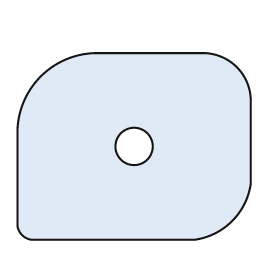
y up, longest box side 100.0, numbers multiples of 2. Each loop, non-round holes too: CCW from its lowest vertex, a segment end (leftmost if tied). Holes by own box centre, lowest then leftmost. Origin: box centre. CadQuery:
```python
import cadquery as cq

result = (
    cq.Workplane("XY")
    .moveTo(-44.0, -40.0)
    .lineTo(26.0, -40.0)
    .threePointArc((42.0, -32.0), (50.0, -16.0))
    .lineTo(50.0, 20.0)
    .threePointArc((44.0, 34.0), (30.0, 40.0))
    .lineTo(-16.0, 40.0)
    .threePointArc((-40.0, 30.0), (-50.0, 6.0))
    .lineTo(-50.0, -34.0)
    .threePointArc((-48.0, -38.0), (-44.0, -40.0))
    .close()
    .moveTo(0.0, 0.0)
    .circle(8.0)
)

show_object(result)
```